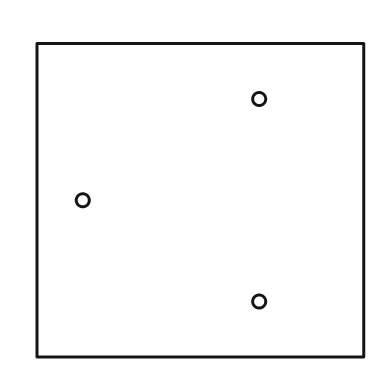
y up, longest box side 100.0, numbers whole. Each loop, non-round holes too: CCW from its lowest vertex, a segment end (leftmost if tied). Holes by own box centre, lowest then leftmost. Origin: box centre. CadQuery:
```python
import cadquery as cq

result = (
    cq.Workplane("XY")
    .moveTo(-50.0, -48.0)
    .lineTo(50.0, -48.0)
    .lineTo(50.0, 48.0)
    .lineTo(-50.0, 48.0)
    .close()
    .moveTo(18.0, -31.0)
    .circle(2.0)
    .moveTo(-36.0, 0.0)
    .circle(2.0)
    .moveTo(18.0, 31.0)
    .circle(2.0)
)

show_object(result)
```